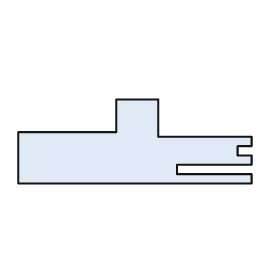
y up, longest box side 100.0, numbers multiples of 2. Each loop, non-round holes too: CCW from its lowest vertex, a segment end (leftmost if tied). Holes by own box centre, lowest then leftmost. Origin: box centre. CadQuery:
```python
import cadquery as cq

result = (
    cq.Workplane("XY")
    .moveTo(-50.0, -18.0)
    .lineTo(50.0, -18.0)
    .lineTo(50.0, -14.0)
    .lineTo(18.0, -14.0)
    .lineTo(18.0, -10.0)
    .lineTo(50.0, -10.0)
    .lineTo(50.0, -6.0)
    .lineTo(44.0, -6.0)
    .lineTo(44.0, -2.0)
    .lineTo(50.0, -2.0)
    .lineTo(50.0, 2.0)
    .lineTo(10.0, 2.0)
    .lineTo(10.0, 18.0)
    .lineTo(-8.0, 18.0)
    .lineTo(-8.0, 4.0)
    .lineTo(-50.0, 4.0)
    .close()
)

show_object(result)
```